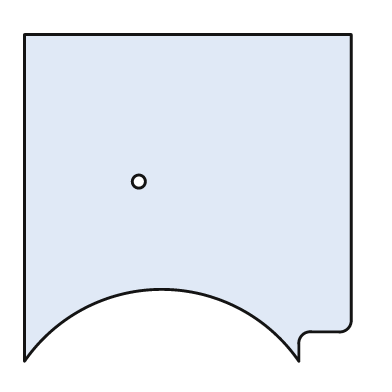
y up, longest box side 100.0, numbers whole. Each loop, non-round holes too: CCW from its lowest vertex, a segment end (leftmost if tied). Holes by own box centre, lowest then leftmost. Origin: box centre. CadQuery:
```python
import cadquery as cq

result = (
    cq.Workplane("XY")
    .moveTo(-50.0, -50.0)
    .threePointArc((-8.0, -28.0), (34.0, -50.0))
    .lineTo(34.0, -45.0)
    .threePointArc((35.0, -42.0), (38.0, -41.0))
    .lineTo(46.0, -41.0)
    .threePointArc((49.0, -40.0), (50.0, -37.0))
    .lineTo(50.0, 50.0)
    .lineTo(-50.0, 50.0)
    .close()
    .moveTo(-15.0, 5.0)
    .circle(2.0)
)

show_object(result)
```